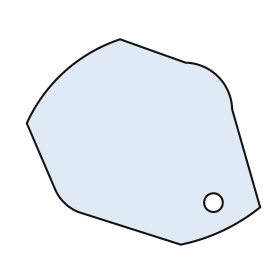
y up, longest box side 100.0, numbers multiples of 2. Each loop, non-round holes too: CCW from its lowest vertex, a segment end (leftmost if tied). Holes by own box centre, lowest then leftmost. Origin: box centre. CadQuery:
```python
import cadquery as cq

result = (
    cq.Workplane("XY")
    .moveTo(16.0, -44.0)
    .threePointArc((34.0, -38.0), (50.0, -28.0))
    .lineTo(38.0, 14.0)
    .threePointArc((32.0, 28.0), (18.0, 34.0))
    .lineTo(-10.0, 44.0)
    .threePointArc((-34.0, 30.0), (-50.0, 8.0))
    .lineTo(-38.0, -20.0)
    .threePointArc((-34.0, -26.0), (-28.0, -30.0))
    .close()
    .moveTo(30.0, -26.0)
    .circle(4.0)
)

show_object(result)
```